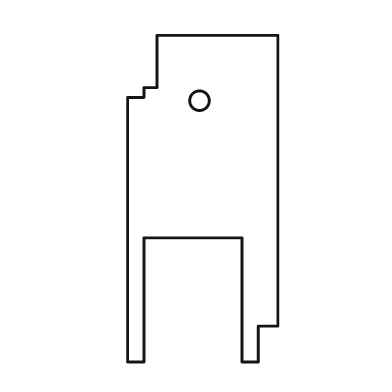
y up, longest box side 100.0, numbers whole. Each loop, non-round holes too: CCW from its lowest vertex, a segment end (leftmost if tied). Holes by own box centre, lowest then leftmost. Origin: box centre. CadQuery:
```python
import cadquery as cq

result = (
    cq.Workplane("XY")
    .moveTo(-23.0, -50.0)
    .lineTo(-18.0, -50.0)
    .lineTo(-18.0, -12.0)
    .lineTo(12.0, -12.0)
    .lineTo(12.0, -50.0)
    .lineTo(17.0, -50.0)
    .lineTo(17.0, -39.0)
    .lineTo(23.0, -39.0)
    .lineTo(23.0, 50.0)
    .lineTo(-14.0, 50.0)
    .lineTo(-14.0, 34.0)
    .lineTo(-18.0, 34.0)
    .lineTo(-18.0, 31.0)
    .lineTo(-23.0, 31.0)
    .close()
    .moveTo(-1.0, 30.0)
    .circle(3.0)
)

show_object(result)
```